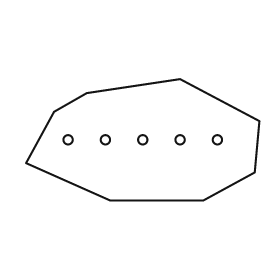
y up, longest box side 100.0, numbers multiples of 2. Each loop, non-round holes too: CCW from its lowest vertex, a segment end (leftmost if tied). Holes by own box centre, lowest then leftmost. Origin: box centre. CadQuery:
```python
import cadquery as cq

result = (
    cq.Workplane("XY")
    .moveTo(-14.0, -26.0)
    .lineTo(26.0, -26.0)
    .lineTo(48.0, -14.0)
    .lineTo(50.0, 8.0)
    .lineTo(16.0, 26.0)
    .lineTo(-24.0, 20.0)
    .lineTo(-38.0, 12.0)
    .lineTo(-50.0, -10.0)
    .close()
    .moveTo(-32.0, 0.0)
    .circle(2.0)
    .moveTo(-16.0, 0.0)
    .circle(2.0)
    .moveTo(0.0, 0.0)
    .circle(2.0)
    .moveTo(16.0, 0.0)
    .circle(2.0)
    .moveTo(32.0, 0.0)
    .circle(2.0)
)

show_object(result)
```